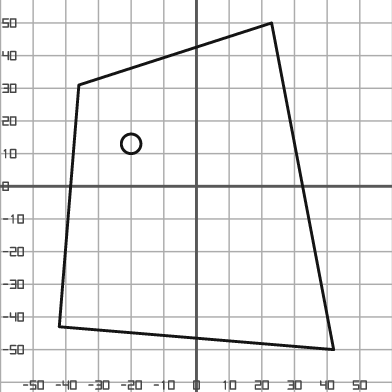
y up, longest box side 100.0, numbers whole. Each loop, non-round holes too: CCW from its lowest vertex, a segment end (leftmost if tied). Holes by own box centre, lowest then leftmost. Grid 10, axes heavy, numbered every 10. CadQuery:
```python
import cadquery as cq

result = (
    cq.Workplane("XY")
    .moveTo(42.0, -50.0)
    .lineTo(23.0, 50.0)
    .lineTo(-36.0, 31.0)
    .lineTo(-42.0, -43.0)
    .close()
    .moveTo(-20.0, 13.0)
    .circle(3.0)
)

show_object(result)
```